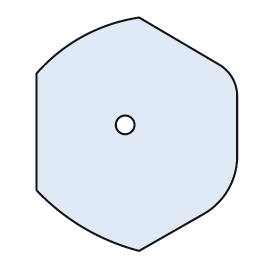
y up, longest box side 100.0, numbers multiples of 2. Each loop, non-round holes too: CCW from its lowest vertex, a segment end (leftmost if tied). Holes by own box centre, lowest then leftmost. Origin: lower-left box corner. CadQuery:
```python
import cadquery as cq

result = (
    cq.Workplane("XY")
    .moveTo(44.0, 0.0)
    .lineTo(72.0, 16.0)
    .threePointArc((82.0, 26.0), (86.0, 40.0))
    .lineTo(86.0, 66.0)
    .threePointArc((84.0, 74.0), (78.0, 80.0))
    .lineTo(44.0, 100.0)
    .threePointArc((20.0, 92.0), (0.0, 76.0))
    .lineTo(0.0, 26.0)
    .threePointArc((20.0, 10.0), (44.0, 0.0))
    .close()
    .moveTo(38.0, 54.0)
    .circle(4.0)
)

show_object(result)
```